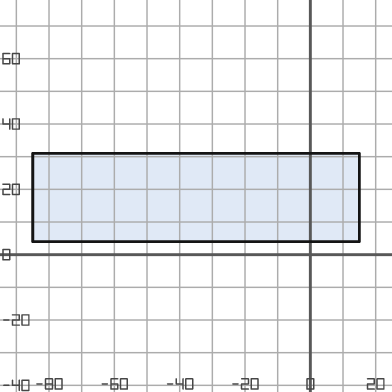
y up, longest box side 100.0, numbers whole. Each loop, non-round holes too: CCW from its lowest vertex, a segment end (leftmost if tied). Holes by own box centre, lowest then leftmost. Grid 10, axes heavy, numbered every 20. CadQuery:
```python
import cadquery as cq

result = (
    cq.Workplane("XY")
    .moveTo(-85.0, 4.0)
    .lineTo(15.0, 4.0)
    .lineTo(15.0, 31.0)
    .lineTo(-85.0, 31.0)
    .close()
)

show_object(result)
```